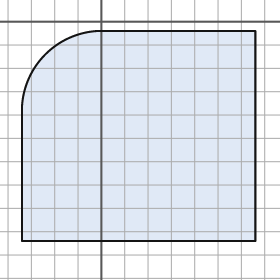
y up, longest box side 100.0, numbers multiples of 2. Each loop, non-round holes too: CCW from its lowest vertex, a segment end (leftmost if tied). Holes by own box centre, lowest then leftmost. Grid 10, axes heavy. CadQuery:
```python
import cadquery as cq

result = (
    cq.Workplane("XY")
    .moveTo(-34.0, -94.0)
    .lineTo(66.0, -94.0)
    .lineTo(66.0, -4.0)
    .lineTo(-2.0, -4.0)
    .threePointArc((-24.0, -14.0), (-34.0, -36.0))
    .close()
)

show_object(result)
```